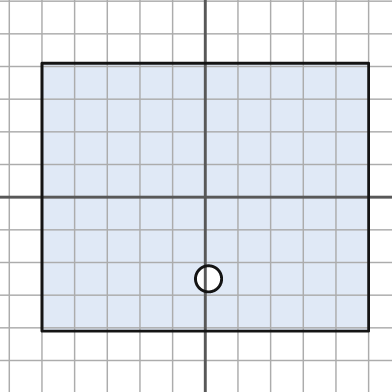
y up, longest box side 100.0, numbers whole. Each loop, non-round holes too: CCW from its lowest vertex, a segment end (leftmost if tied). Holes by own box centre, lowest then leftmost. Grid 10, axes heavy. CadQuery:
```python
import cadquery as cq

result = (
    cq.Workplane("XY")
    .moveTo(-50.0, -41.0)
    .lineTo(50.0, -41.0)
    .lineTo(50.0, 41.0)
    .lineTo(-50.0, 41.0)
    .close()
    .moveTo(1.0, -25.0)
    .circle(4.0)
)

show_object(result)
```